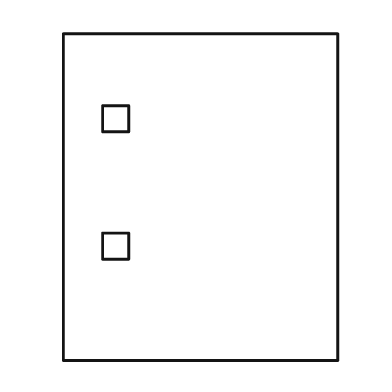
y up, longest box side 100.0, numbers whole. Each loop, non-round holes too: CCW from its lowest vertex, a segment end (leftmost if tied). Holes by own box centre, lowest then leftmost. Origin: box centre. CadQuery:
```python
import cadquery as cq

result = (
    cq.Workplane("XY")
    .moveTo(-42.0, -50.0)
    .lineTo(42.0, -50.0)
    .lineTo(42.0, 50.0)
    .lineTo(-42.0, 50.0)
    .close()
    .moveTo(-30.0, -19.0)
    .lineTo(-22.0, -19.0)
    .lineTo(-22.0, -11.0)
    .lineTo(-30.0, -11.0)
    .close()
    .moveTo(-30.0, 20.0)
    .lineTo(-22.0, 20.0)
    .lineTo(-22.0, 28.0)
    .lineTo(-30.0, 28.0)
    .close()
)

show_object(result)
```